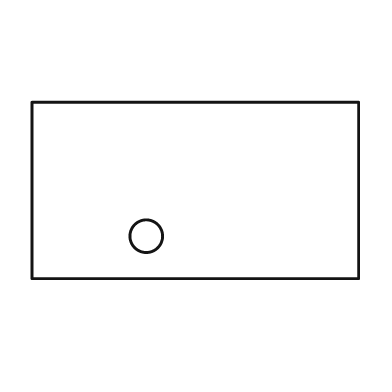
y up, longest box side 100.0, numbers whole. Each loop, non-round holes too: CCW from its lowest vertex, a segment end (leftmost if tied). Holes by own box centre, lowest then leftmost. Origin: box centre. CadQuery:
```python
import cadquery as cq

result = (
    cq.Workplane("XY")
    .moveTo(-50.0, -27.0)
    .lineTo(50.0, -27.0)
    .lineTo(50.0, 27.0)
    .lineTo(-50.0, 27.0)
    .close()
    .moveTo(-15.0, -14.0)
    .circle(5.0)
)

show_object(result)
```